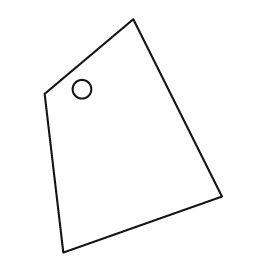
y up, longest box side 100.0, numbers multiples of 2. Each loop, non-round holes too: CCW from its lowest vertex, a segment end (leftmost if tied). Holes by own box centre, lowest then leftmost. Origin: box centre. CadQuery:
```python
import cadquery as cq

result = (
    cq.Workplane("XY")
    .moveTo(-30.0, -50.0)
    .lineTo(38.0, -26.0)
    .lineTo(0.0, 50.0)
    .lineTo(-38.0, 18.0)
    .close()
    .moveTo(-22.0, 20.0)
    .circle(4.0)
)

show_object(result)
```